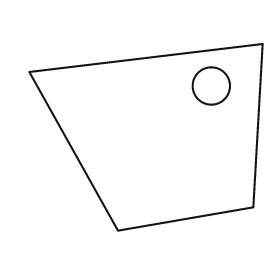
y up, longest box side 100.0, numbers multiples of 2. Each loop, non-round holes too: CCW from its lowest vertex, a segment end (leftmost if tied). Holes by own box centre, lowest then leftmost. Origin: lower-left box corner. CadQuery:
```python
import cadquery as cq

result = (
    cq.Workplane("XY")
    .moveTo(38.0, 0.0)
    .lineTo(96.0, 10.0)
    .lineTo(100.0, 80.0)
    .lineTo(0.0, 68.0)
    .close()
    .moveTo(78.0, 62.0)
    .circle(8.0)
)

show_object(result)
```